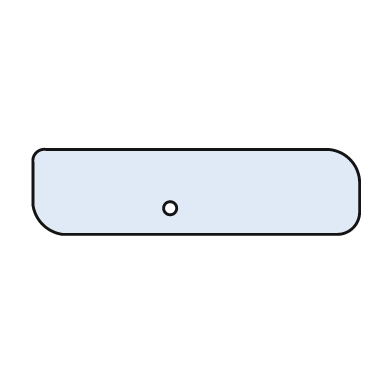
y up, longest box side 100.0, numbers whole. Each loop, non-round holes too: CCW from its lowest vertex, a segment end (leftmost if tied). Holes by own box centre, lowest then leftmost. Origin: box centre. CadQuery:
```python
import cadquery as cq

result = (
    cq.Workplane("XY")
    .moveTo(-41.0, -13.0)
    .lineTo(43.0, -13.0)
    .threePointArc((48.0, -11.0), (50.0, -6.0))
    .lineTo(50.0, 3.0)
    .threePointArc((47.0, 10.0), (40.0, 13.0))
    .lineTo(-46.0, 13.0)
    .threePointArc((-49.0, 12.0), (-50.0, 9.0))
    .lineTo(-50.0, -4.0)
    .threePointArc((-47.0, -10.0), (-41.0, -13.0))
    .close()
    .moveTo(-8.0, -5.0)
    .circle(2.0)
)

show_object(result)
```